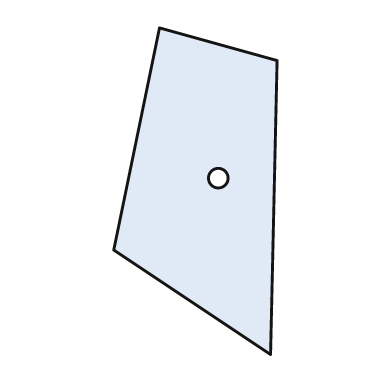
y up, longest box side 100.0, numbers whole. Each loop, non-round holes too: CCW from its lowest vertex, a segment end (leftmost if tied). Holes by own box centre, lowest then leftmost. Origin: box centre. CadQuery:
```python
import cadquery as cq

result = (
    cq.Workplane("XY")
    .moveTo(23.0, -50.0)
    .lineTo(25.0, 40.0)
    .lineTo(-11.0, 50.0)
    .lineTo(-25.0, -18.0)
    .close()
    .moveTo(7.0, 4.0)
    .circle(3.0)
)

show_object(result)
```